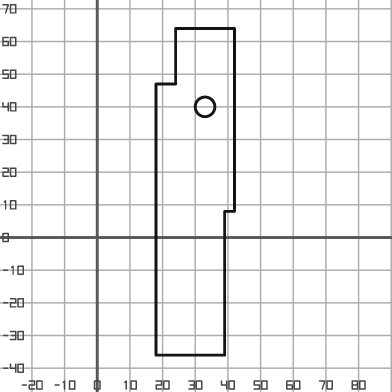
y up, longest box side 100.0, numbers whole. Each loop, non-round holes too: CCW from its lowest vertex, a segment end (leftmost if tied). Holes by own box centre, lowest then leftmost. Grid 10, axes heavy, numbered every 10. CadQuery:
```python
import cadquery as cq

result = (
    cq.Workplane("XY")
    .moveTo(18.0, -36.0)
    .lineTo(39.0, -36.0)
    .lineTo(39.0, 8.0)
    .lineTo(42.0, 8.0)
    .lineTo(42.0, 64.0)
    .lineTo(24.0, 64.0)
    .lineTo(24.0, 47.0)
    .lineTo(18.0, 47.0)
    .close()
    .moveTo(33.0, 40.0)
    .circle(3.0)
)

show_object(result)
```